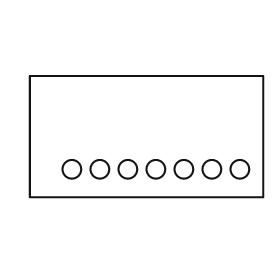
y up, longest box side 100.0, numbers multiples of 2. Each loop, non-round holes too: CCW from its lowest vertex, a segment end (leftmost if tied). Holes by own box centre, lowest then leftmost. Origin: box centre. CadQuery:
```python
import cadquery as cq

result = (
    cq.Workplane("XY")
    .moveTo(-50.0, -26.0)
    .lineTo(50.0, -26.0)
    .lineTo(50.0, 26.0)
    .lineTo(-50.0, 26.0)
    .close()
    .moveTo(-32.0, -14.0)
    .circle(4.0)
    .moveTo(-20.0, -14.0)
    .circle(4.0)
    .moveTo(-8.0, -14.0)
    .circle(4.0)
    .moveTo(4.0, -14.0)
    .circle(4.0)
    .moveTo(16.0, -14.0)
    .circle(4.0)
    .moveTo(28.0, -14.0)
    .circle(4.0)
    .moveTo(40.0, -14.0)
    .circle(4.0)
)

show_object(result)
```